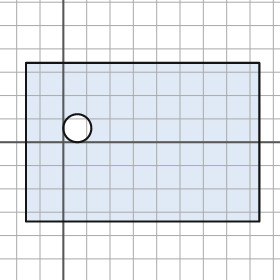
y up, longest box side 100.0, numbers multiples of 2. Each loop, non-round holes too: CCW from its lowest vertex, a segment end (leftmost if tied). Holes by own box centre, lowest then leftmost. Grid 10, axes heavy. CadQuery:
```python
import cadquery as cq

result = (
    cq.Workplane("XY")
    .moveTo(-16.0, -34.0)
    .lineTo(84.0, -34.0)
    .lineTo(84.0, 34.0)
    .lineTo(-16.0, 34.0)
    .close()
    .moveTo(6.0, 6.0)
    .circle(6.0)
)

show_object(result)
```